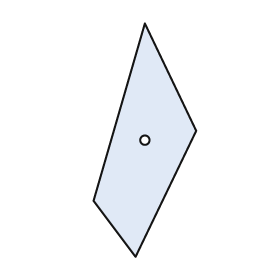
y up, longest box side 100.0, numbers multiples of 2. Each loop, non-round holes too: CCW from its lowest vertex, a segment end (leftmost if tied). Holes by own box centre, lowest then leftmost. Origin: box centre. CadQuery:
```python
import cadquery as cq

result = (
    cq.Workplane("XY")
    .moveTo(-4.0, -50.0)
    .lineTo(22.0, 4.0)
    .lineTo(0.0, 50.0)
    .lineTo(-22.0, -26.0)
    .close()
    .moveTo(0.0, 0.0)
    .circle(2.0)
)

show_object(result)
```